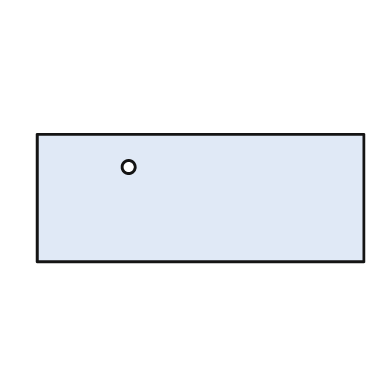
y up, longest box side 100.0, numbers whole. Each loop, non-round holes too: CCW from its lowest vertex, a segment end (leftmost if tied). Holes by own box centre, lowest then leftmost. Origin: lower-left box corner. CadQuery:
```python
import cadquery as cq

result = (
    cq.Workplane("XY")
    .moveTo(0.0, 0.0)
    .lineTo(100.0, 0.0)
    .lineTo(100.0, 39.0)
    .lineTo(0.0, 39.0)
    .close()
    .moveTo(28.0, 29.0)
    .circle(2.0)
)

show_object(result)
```